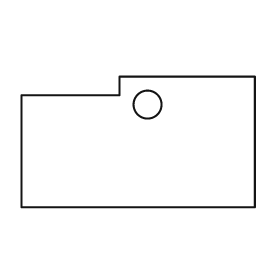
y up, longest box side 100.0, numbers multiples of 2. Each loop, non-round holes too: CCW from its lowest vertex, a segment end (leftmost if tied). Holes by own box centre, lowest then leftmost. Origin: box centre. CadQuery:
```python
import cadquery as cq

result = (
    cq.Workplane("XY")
    .moveTo(-50.0, -28.0)
    .lineTo(50.0, -28.0)
    .lineTo(50.0, 28.0)
    .lineTo(-8.0, 28.0)
    .lineTo(-8.0, 20.0)
    .lineTo(-50.0, 20.0)
    .close()
    .moveTo(4.0, 16.0)
    .circle(6.0)
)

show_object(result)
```